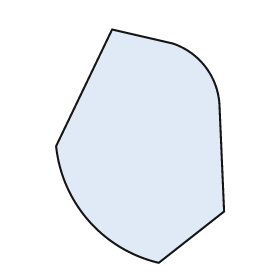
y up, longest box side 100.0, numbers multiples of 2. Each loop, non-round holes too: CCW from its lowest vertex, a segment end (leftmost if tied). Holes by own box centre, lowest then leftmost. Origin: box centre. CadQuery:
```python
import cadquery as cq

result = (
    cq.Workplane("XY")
    .moveTo(8.0, -50.0)
    .lineTo(36.0, -28.0)
    .lineTo(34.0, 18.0)
    .threePointArc((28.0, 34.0), (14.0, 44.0))
    .lineTo(-12.0, 50.0)
    .lineTo(-36.0, 0.0)
    .threePointArc((-22.0, -32.0), (8.0, -50.0))
    .close()
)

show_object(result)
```